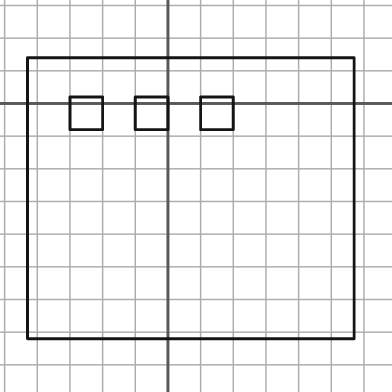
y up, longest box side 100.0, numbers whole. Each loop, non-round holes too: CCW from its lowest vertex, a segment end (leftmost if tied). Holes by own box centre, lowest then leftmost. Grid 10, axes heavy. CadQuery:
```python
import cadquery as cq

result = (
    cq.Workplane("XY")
    .moveTo(-43.0, -72.0)
    .lineTo(57.0, -72.0)
    .lineTo(57.0, 14.0)
    .lineTo(-43.0, 14.0)
    .close()
    .moveTo(-30.0, -8.0)
    .lineTo(-20.0, -8.0)
    .lineTo(-20.0, 2.0)
    .lineTo(-30.0, 2.0)
    .close()
    .moveTo(-10.0, -8.0)
    .lineTo(0.0, -8.0)
    .lineTo(0.0, 2.0)
    .lineTo(-10.0, 2.0)
    .close()
    .moveTo(10.0, -8.0)
    .lineTo(20.0, -8.0)
    .lineTo(20.0, 2.0)
    .lineTo(10.0, 2.0)
    .close()
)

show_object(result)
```